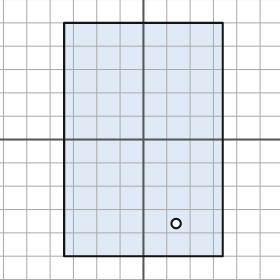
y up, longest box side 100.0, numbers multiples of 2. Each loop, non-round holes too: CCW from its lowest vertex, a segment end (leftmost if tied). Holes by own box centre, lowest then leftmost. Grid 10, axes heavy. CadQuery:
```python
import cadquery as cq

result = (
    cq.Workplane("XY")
    .moveTo(-34.0, -50.0)
    .lineTo(34.0, -50.0)
    .lineTo(34.0, 50.0)
    .lineTo(-34.0, 50.0)
    .close()
    .moveTo(14.0, -36.0)
    .circle(2.0)
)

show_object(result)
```